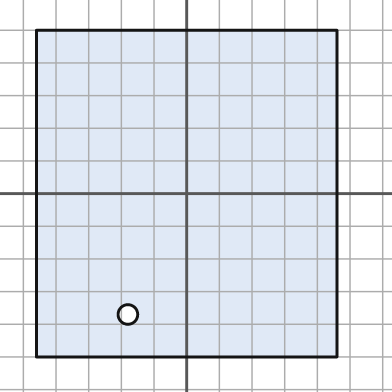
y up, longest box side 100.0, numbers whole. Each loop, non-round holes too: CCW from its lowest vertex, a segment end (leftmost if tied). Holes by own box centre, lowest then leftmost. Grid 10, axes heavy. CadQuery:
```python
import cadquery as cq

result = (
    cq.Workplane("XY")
    .moveTo(-46.0, -50.0)
    .lineTo(46.0, -50.0)
    .lineTo(46.0, 50.0)
    .lineTo(-46.0, 50.0)
    .close()
    .moveTo(-18.0, -37.0)
    .circle(3.0)
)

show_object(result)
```